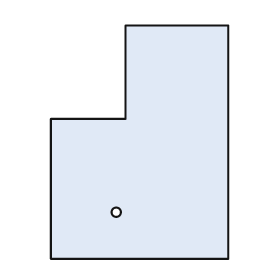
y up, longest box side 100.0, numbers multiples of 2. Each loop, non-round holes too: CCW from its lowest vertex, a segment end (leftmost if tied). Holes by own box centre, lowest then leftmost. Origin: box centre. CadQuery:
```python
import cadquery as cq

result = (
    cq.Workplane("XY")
    .moveTo(-38.0, -50.0)
    .lineTo(38.0, -50.0)
    .lineTo(38.0, 50.0)
    .lineTo(-6.0, 50.0)
    .lineTo(-6.0, 10.0)
    .lineTo(-38.0, 10.0)
    .close()
    .moveTo(-10.0, -30.0)
    .circle(2.0)
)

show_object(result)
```